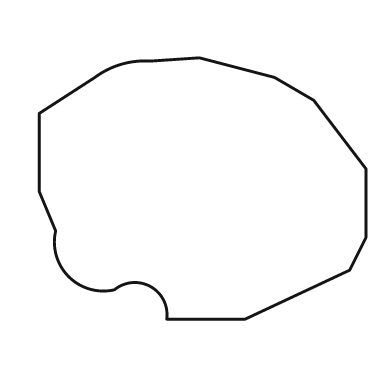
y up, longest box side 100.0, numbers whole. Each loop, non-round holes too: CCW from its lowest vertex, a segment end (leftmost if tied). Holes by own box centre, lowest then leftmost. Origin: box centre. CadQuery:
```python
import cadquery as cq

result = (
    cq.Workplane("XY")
    .moveTo(-11.0, -40.0)
    .lineTo(13.0, -40.0)
    .lineTo(45.0, -25.0)
    .lineTo(50.0, -15.0)
    .lineTo(50.0, 6.0)
    .lineTo(34.0, 27.0)
    .lineTo(22.0, 34.0)
    .lineTo(-1.0, 40.0)
    .lineTo(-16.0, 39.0)
    .threePointArc((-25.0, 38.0), (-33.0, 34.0))
    .lineTo(-50.0, 23.0)
    .lineTo(-50.0, -1.0)
    .lineTo(-45.0, -13.0)
    .threePointArc((-41.0, -27.0), (-27.0, -31.0))
    .threePointArc((-16.0, -30.0), (-11.0, -40.0))
    .close()
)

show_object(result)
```